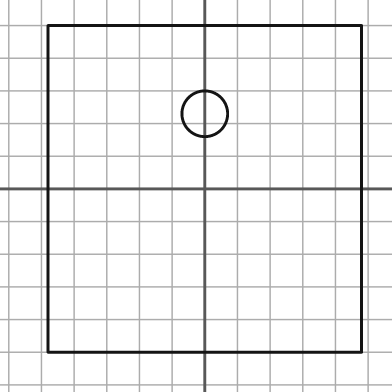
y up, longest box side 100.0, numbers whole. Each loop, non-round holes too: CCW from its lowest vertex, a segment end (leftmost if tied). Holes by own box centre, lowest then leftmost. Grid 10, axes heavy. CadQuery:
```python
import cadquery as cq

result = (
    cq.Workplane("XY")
    .moveTo(-48.0, -50.0)
    .lineTo(48.0, -50.0)
    .lineTo(48.0, 50.0)
    .lineTo(-48.0, 50.0)
    .close()
    .moveTo(0.0, 23.0)
    .circle(7.0)
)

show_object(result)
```